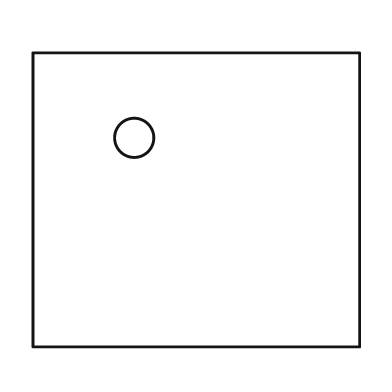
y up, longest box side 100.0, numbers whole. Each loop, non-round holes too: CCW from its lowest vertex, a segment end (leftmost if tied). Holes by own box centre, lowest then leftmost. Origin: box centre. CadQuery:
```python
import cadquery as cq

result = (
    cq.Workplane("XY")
    .moveTo(-50.0, -45.0)
    .lineTo(50.0, -45.0)
    .lineTo(50.0, 45.0)
    .lineTo(-50.0, 45.0)
    .close()
    .moveTo(-19.0, 19.0)
    .circle(6.0)
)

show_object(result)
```